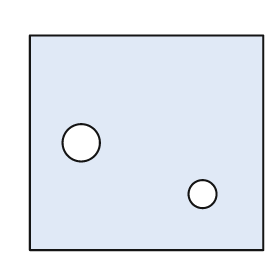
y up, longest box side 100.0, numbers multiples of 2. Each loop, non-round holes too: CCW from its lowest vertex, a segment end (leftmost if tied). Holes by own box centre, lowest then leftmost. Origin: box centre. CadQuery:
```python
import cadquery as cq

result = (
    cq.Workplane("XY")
    .moveTo(-50.0, -46.0)
    .lineTo(50.0, -46.0)
    .lineTo(50.0, 46.0)
    .lineTo(-50.0, 46.0)
    .close()
    .moveTo(24.0, -22.0)
    .circle(6.0)
    .moveTo(-28.0, 0.0)
    .circle(8.0)
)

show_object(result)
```